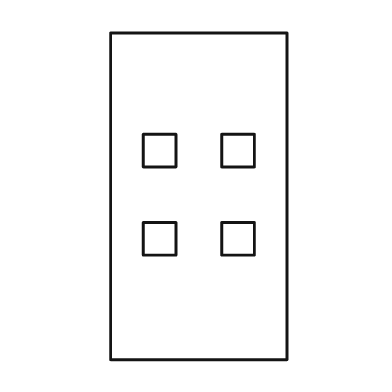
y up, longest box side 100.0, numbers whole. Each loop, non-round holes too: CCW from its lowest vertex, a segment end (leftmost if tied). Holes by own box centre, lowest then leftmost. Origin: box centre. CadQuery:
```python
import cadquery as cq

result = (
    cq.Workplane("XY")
    .moveTo(-27.0, -50.0)
    .lineTo(27.0, -50.0)
    .lineTo(27.0, 50.0)
    .lineTo(-27.0, 50.0)
    .close()
    .moveTo(-17.0, -18.0)
    .lineTo(-7.0, -18.0)
    .lineTo(-7.0, -8.0)
    .lineTo(-17.0, -8.0)
    .close()
    .moveTo(7.0, -18.0)
    .lineTo(17.0, -18.0)
    .lineTo(17.0, -8.0)
    .lineTo(7.0, -8.0)
    .close()
    .moveTo(-17.0, 9.0)
    .lineTo(-7.0, 9.0)
    .lineTo(-7.0, 19.0)
    .lineTo(-17.0, 19.0)
    .close()
    .moveTo(7.0, 9.0)
    .lineTo(17.0, 9.0)
    .lineTo(17.0, 19.0)
    .lineTo(7.0, 19.0)
    .close()
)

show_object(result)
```